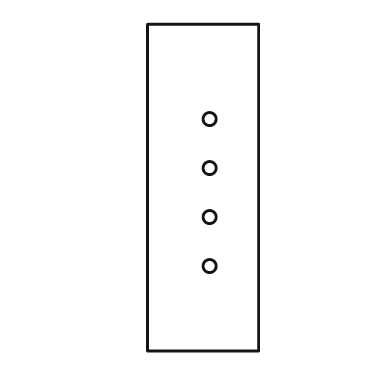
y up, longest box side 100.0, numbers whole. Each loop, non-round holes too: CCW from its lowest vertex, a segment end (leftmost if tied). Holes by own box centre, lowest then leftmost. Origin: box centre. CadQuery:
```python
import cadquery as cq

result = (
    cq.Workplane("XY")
    .moveTo(-17.0, -50.0)
    .lineTo(17.0, -50.0)
    .lineTo(17.0, 50.0)
    .lineTo(-17.0, 50.0)
    .close()
    .moveTo(2.0, -24.0)
    .circle(2.0)
    .moveTo(2.0, -9.0)
    .circle(2.0)
    .moveTo(2.0, 6.0)
    .circle(2.0)
    .moveTo(2.0, 21.0)
    .circle(2.0)
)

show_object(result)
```